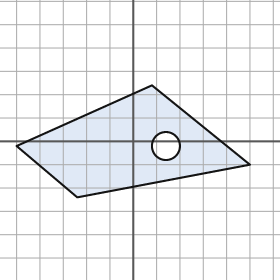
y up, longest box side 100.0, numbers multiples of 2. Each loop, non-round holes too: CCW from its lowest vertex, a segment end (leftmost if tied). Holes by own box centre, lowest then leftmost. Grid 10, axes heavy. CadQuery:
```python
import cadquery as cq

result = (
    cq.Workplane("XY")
    .moveTo(-24.0, -24.0)
    .lineTo(50.0, -10.0)
    .lineTo(8.0, 24.0)
    .lineTo(-50.0, -2.0)
    .close()
    .moveTo(14.0, -2.0)
    .circle(6.0)
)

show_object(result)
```